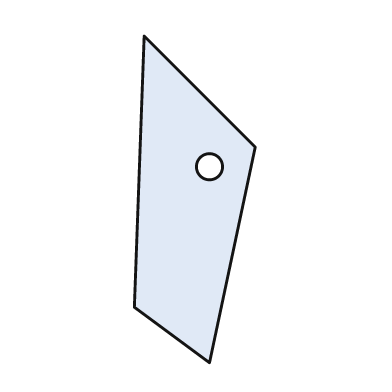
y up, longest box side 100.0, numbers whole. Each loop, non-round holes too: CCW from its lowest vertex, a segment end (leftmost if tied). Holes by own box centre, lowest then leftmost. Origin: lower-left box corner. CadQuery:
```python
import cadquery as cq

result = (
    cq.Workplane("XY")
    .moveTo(23.0, 0.0)
    .lineTo(37.0, 66.0)
    .lineTo(3.0, 100.0)
    .lineTo(0.0, 17.0)
    .close()
    .moveTo(23.0, 60.0)
    .circle(4.0)
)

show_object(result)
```